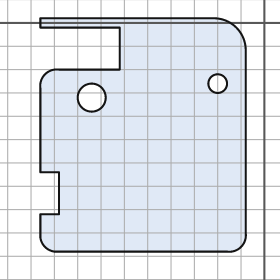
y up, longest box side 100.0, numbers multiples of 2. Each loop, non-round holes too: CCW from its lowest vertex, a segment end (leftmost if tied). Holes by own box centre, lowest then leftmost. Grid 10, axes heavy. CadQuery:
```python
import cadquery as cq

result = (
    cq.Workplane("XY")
    .moveTo(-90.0, -98.0)
    .lineTo(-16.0, -98.0)
    .threePointArc((-10.0, -96.0), (-8.0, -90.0))
    .lineTo(-8.0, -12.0)
    .threePointArc((-12.0, -2.0), (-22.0, 2.0))
    .lineTo(-96.0, 2.0)
    .lineTo(-96.0, -2.0)
    .lineTo(-62.0, -2.0)
    .lineTo(-62.0, -20.0)
    .lineTo(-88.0, -20.0)
    .threePointArc((-94.0, -22.0), (-96.0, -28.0))
    .lineTo(-96.0, -64.0)
    .lineTo(-88.0, -64.0)
    .lineTo(-88.0, -82.0)
    .lineTo(-96.0, -82.0)
    .lineTo(-96.0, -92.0)
    .threePointArc((-94.0, -96.0), (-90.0, -98.0))
    .close()
    .moveTo(-74.0, -32.0)
    .circle(6.0)
    .moveTo(-20.0, -26.0)
    .circle(4.0)
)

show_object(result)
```